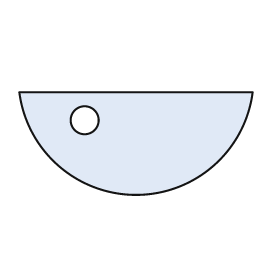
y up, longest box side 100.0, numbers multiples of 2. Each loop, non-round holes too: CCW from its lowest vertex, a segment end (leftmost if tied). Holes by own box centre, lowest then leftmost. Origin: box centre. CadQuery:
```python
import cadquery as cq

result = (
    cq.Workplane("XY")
    .moveTo(-50.0, 22.0)
    .threePointArc((0.0, -22.0), (50.0, 22.0))
    .close()
    .moveTo(-22.0, 10.0)
    .circle(6.0)
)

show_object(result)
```